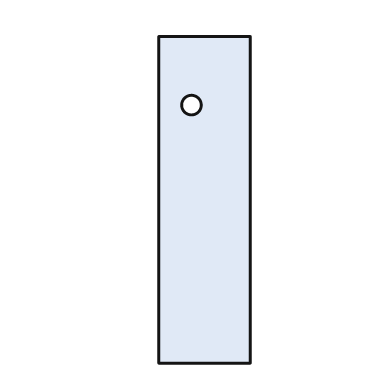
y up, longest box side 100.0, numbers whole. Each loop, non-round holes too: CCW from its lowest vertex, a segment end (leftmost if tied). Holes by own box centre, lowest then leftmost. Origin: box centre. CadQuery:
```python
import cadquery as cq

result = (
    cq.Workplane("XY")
    .moveTo(-14.0, -50.0)
    .lineTo(14.0, -50.0)
    .lineTo(14.0, 50.0)
    .lineTo(-14.0, 50.0)
    .close()
    .moveTo(-4.0, 29.0)
    .circle(3.0)
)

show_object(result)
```